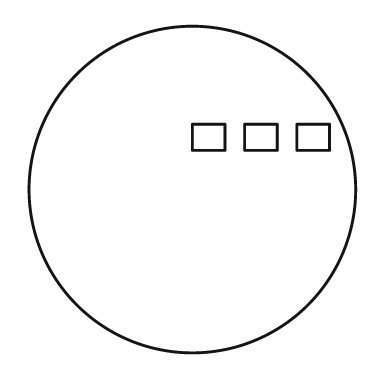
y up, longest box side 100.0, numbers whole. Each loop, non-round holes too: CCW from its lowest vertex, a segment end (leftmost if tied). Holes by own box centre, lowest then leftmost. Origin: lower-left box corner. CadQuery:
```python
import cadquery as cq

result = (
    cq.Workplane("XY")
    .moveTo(50.0, 50.0)
    .circle(50.0)
    .moveTo(50.0, 62.0)
    .lineTo(60.0, 62.0)
    .lineTo(60.0, 70.0)
    .lineTo(50.0, 70.0)
    .close()
    .moveTo(66.0, 62.0)
    .lineTo(76.0, 62.0)
    .lineTo(76.0, 70.0)
    .lineTo(66.0, 70.0)
    .close()
    .moveTo(82.0, 62.0)
    .lineTo(92.0, 62.0)
    .lineTo(92.0, 70.0)
    .lineTo(82.0, 70.0)
    .close()
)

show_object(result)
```